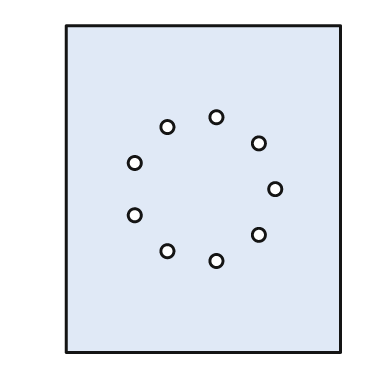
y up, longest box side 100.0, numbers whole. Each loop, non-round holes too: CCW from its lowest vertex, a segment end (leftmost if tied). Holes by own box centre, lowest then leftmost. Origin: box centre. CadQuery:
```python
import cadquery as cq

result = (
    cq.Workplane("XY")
    .moveTo(-42.0, -50.0)
    .lineTo(42.0, -50.0)
    .lineTo(42.0, 50.0)
    .lineTo(-42.0, 50.0)
    .close()
    .moveTo(4.0, -22.0)
    .circle(2.0)
    .moveTo(-11.0, -19.0)
    .circle(2.0)
    .moveTo(17.0, -14.0)
    .circle(2.0)
    .moveTo(-21.0, -8.0)
    .circle(2.0)
    .moveTo(22.0, 0.0)
    .circle(2.0)
    .moveTo(-21.0, 8.0)
    .circle(2.0)
    .moveTo(17.0, 14.0)
    .circle(2.0)
    .moveTo(-11.0, 19.0)
    .circle(2.0)
    .moveTo(4.0, 22.0)
    .circle(2.0)
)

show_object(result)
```